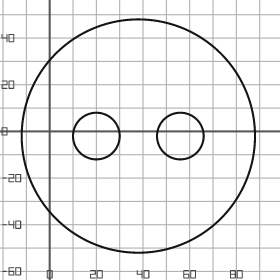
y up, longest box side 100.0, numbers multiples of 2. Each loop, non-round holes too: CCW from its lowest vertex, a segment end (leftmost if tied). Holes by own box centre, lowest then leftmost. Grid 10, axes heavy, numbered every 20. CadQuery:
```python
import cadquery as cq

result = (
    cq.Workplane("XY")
    .moveTo(38.0, -2.0)
    .circle(50.0)
    .moveTo(20.0, -2.0)
    .circle(10.0)
    .moveTo(56.0, -2.0)
    .circle(10.0)
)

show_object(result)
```